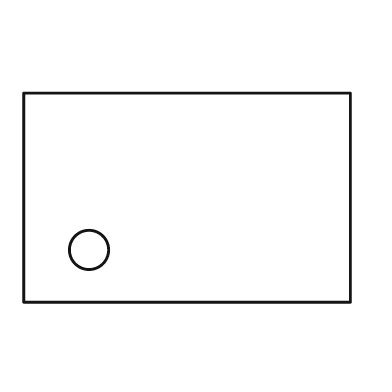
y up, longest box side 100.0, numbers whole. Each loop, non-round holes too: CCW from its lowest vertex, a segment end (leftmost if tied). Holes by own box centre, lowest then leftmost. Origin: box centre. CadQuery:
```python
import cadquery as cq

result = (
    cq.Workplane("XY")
    .moveTo(-50.0, -32.0)
    .lineTo(50.0, -32.0)
    .lineTo(50.0, 32.0)
    .lineTo(-50.0, 32.0)
    .close()
    .moveTo(-30.0, -16.0)
    .circle(6.0)
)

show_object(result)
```